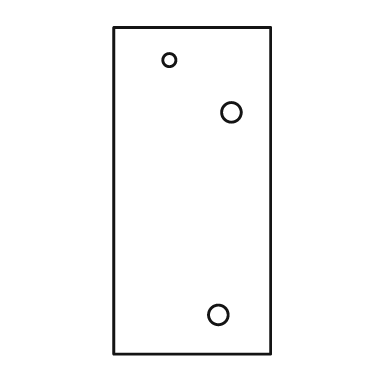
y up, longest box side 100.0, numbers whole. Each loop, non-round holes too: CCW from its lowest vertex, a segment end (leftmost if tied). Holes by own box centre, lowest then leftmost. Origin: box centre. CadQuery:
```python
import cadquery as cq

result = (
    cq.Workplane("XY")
    .moveTo(-24.0, -50.0)
    .lineTo(24.0, -50.0)
    .lineTo(24.0, 50.0)
    .lineTo(-24.0, 50.0)
    .close()
    .moveTo(8.0, -38.0)
    .circle(3.0)
    .moveTo(12.0, 24.0)
    .circle(3.0)
    .moveTo(-7.0, 40.0)
    .circle(2.0)
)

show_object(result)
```